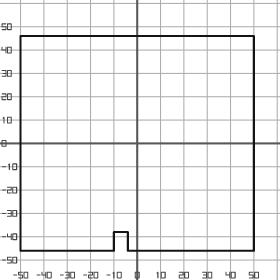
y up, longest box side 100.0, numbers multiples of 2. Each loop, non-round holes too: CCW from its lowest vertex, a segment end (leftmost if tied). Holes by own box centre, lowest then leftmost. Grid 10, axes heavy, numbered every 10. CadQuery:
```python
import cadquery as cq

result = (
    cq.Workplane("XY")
    .moveTo(-50.0, -46.0)
    .lineTo(-10.0, -46.0)
    .lineTo(-10.0, -38.0)
    .lineTo(-4.0, -38.0)
    .lineTo(-4.0, -46.0)
    .lineTo(50.0, -46.0)
    .lineTo(50.0, 46.0)
    .lineTo(-50.0, 46.0)
    .close()
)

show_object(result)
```